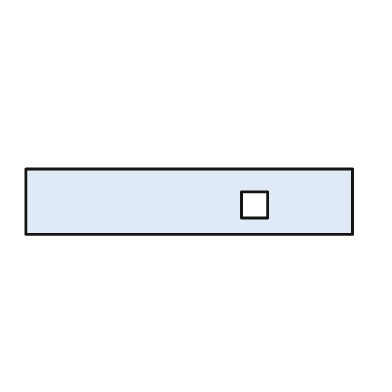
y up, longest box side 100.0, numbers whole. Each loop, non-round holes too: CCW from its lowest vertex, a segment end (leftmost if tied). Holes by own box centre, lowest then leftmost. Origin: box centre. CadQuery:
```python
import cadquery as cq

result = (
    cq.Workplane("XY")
    .moveTo(-50.0, -10.0)
    .lineTo(50.0, -10.0)
    .lineTo(50.0, 10.0)
    .lineTo(-50.0, 10.0)
    .close()
    .moveTo(16.0, -5.0)
    .lineTo(24.0, -5.0)
    .lineTo(24.0, 3.0)
    .lineTo(16.0, 3.0)
    .close()
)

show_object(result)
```